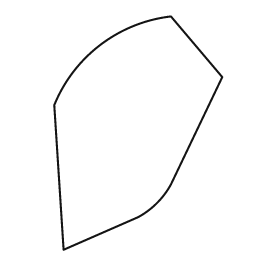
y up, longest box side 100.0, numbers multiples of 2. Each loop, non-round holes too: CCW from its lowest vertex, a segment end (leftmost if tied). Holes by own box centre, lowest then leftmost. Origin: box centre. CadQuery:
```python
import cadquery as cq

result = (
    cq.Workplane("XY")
    .moveTo(-32.0, -50.0)
    .lineTo(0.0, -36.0)
    .threePointArc((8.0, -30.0), (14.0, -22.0))
    .lineTo(36.0, 24.0)
    .lineTo(14.0, 50.0)
    .threePointArc((-16.0, 38.0), (-36.0, 12.0))
    .close()
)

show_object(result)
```